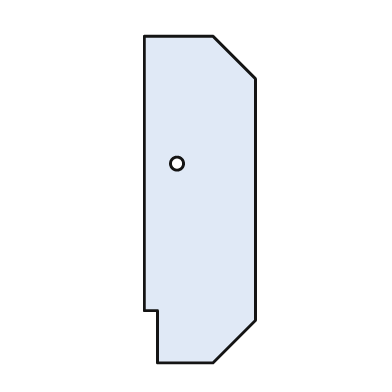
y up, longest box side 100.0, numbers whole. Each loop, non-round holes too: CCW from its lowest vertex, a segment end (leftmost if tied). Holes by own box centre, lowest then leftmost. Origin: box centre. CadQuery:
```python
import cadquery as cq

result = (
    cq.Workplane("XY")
    .moveTo(-13.0, -50.0)
    .lineTo(4.0, -50.0)
    .lineTo(17.0, -37.0)
    .lineTo(17.0, 37.0)
    .lineTo(4.0, 50.0)
    .lineTo(-17.0, 50.0)
    .lineTo(-17.0, -34.0)
    .lineTo(-13.0, -34.0)
    .close()
    .moveTo(-7.0, 11.0)
    .circle(2.0)
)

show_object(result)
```